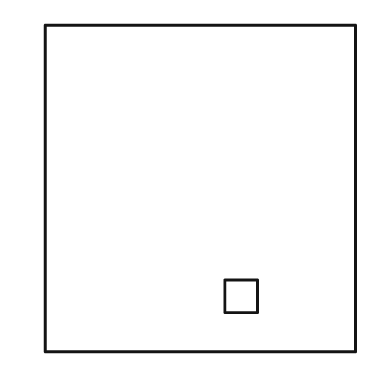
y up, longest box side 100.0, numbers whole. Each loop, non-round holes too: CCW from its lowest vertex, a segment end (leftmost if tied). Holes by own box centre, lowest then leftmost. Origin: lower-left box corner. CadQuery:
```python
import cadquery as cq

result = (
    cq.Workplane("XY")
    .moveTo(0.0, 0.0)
    .lineTo(95.0, 0.0)
    .lineTo(95.0, 100.0)
    .lineTo(0.0, 100.0)
    .close()
    .moveTo(55.0, 12.0)
    .lineTo(65.0, 12.0)
    .lineTo(65.0, 22.0)
    .lineTo(55.0, 22.0)
    .close()
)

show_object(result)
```